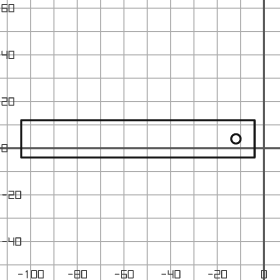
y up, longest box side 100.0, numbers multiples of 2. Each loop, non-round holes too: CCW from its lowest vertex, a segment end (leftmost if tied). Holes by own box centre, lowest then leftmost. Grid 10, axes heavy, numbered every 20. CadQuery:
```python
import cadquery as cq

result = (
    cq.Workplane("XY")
    .moveTo(-104.0, -4.0)
    .lineTo(-4.0, -4.0)
    .lineTo(-4.0, 12.0)
    .lineTo(-104.0, 12.0)
    .close()
    .moveTo(-12.0, 4.0)
    .circle(2.0)
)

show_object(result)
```